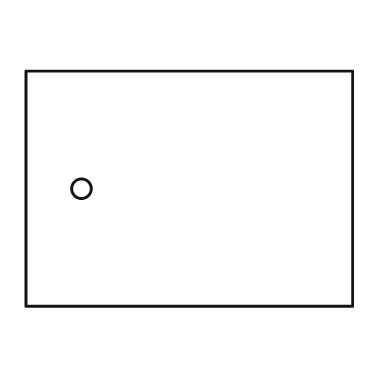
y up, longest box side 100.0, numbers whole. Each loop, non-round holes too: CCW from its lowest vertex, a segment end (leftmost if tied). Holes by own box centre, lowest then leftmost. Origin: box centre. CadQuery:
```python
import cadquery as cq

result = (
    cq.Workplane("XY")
    .moveTo(-50.0, -36.0)
    .lineTo(50.0, -36.0)
    .lineTo(50.0, 36.0)
    .lineTo(-50.0, 36.0)
    .close()
    .moveTo(-33.0, 0.0)
    .circle(3.0)
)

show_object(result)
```